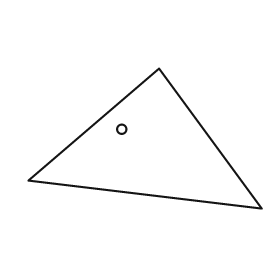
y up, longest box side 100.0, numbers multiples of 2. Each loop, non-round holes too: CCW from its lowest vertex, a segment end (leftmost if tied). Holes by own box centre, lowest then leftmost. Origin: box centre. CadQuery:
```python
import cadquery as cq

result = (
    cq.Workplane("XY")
    .moveTo(50.0, -30.0)
    .lineTo(6.0, 30.0)
    .lineTo(-50.0, -18.0)
    .close()
    .moveTo(-10.0, 4.0)
    .circle(2.0)
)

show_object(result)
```